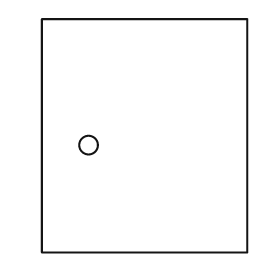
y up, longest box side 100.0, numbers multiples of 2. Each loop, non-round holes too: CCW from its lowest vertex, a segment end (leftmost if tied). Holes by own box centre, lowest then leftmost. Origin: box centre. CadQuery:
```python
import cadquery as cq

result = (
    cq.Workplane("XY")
    .moveTo(-44.0, -50.0)
    .lineTo(44.0, -50.0)
    .lineTo(44.0, 50.0)
    .lineTo(-44.0, 50.0)
    .close()
    .moveTo(-24.0, -4.0)
    .circle(4.0)
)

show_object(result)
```